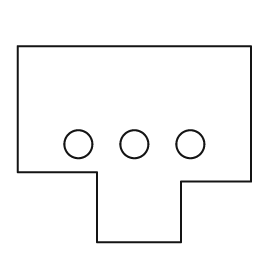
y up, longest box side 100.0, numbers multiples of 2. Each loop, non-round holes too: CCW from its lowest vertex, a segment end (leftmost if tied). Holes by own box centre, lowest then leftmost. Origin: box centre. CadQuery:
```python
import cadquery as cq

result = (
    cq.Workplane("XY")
    .moveTo(-16.0, -42.0)
    .lineTo(20.0, -42.0)
    .lineTo(20.0, -16.0)
    .lineTo(50.0, -16.0)
    .lineTo(50.0, 42.0)
    .lineTo(-50.0, 42.0)
    .lineTo(-50.0, -12.0)
    .lineTo(-16.0, -12.0)
    .close()
    .moveTo(-24.0, 0.0)
    .circle(6.0)
    .moveTo(0.0, 0.0)
    .circle(6.0)
    .moveTo(24.0, 0.0)
    .circle(6.0)
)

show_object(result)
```